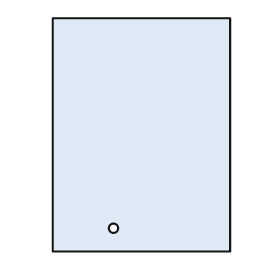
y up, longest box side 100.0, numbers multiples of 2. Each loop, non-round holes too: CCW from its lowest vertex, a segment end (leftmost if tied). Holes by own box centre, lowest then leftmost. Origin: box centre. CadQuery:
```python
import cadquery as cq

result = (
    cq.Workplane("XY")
    .moveTo(-38.0, -50.0)
    .lineTo(38.0, -50.0)
    .lineTo(38.0, 50.0)
    .lineTo(-38.0, 50.0)
    .close()
    .moveTo(-12.0, -40.0)
    .circle(2.0)
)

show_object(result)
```